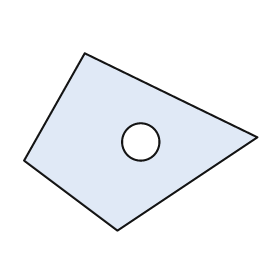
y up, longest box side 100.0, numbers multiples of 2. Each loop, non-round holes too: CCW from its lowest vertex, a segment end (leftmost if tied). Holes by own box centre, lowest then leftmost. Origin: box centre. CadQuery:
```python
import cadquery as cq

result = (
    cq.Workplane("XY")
    .moveTo(-10.0, -38.0)
    .lineTo(50.0, 2.0)
    .lineTo(-24.0, 38.0)
    .lineTo(-50.0, -8.0)
    .close()
    .moveTo(0.0, 0.0)
    .circle(8.0)
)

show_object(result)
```